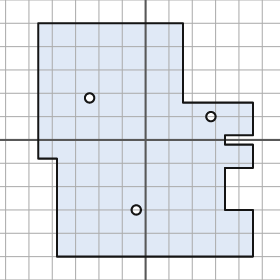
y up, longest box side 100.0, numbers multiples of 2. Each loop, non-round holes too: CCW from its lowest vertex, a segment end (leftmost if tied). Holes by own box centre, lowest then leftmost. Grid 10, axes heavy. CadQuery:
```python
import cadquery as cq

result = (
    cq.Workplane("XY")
    .moveTo(-38.0, -50.0)
    .lineTo(46.0, -50.0)
    .lineTo(46.0, -30.0)
    .lineTo(34.0, -30.0)
    .lineTo(34.0, -12.0)
    .lineTo(46.0, -12.0)
    .lineTo(46.0, -2.0)
    .lineTo(34.0, -2.0)
    .lineTo(34.0, 2.0)
    .lineTo(46.0, 2.0)
    .lineTo(46.0, 16.0)
    .lineTo(16.0, 16.0)
    .lineTo(16.0, 50.0)
    .lineTo(-46.0, 50.0)
    .lineTo(-46.0, -8.0)
    .lineTo(-38.0, -8.0)
    .close()
    .moveTo(-4.0, -30.0)
    .circle(2.0)
    .moveTo(28.0, 10.0)
    .circle(2.0)
    .moveTo(-24.0, 18.0)
    .circle(2.0)
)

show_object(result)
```